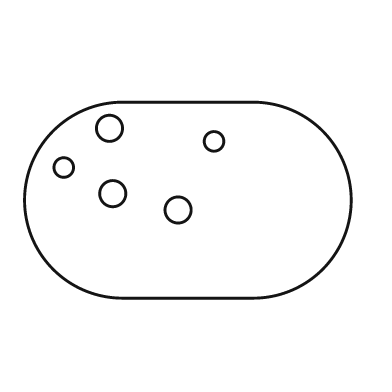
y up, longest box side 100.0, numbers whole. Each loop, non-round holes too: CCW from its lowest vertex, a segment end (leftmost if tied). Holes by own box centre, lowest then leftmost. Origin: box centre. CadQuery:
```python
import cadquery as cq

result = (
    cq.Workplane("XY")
    .moveTo(-20.0, -30.0)
    .lineTo(20.0, -30.0)
    .threePointArc((50.0, 0.0), (20.0, 30.0))
    .lineTo(-20.0, 30.0)
    .threePointArc((-50.0, 0.0), (-20.0, -30.0))
    .close()
    .moveTo(-3.0, -3.0)
    .circle(4.0)
    .moveTo(-23.0, 2.0)
    .circle(4.0)
    .moveTo(-38.0, 10.0)
    .circle(3.0)
    .moveTo(8.0, 18.0)
    .circle(3.0)
    .moveTo(-24.0, 22.0)
    .circle(4.0)
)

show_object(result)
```